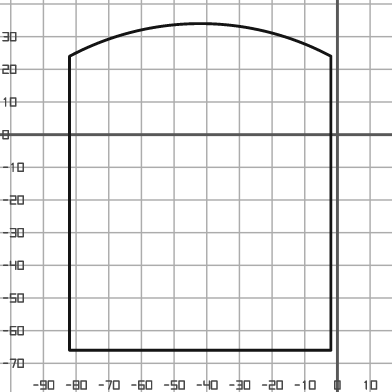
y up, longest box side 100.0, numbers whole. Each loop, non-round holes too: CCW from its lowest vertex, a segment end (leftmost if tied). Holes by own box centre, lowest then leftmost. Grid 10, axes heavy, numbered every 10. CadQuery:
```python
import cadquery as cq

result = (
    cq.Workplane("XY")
    .moveTo(-82.0, -66.0)
    .lineTo(-2.0, -66.0)
    .lineTo(-2.0, 24.0)
    .threePointArc((-42.0, 34.0), (-82.0, 24.0))
    .close()
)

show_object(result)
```